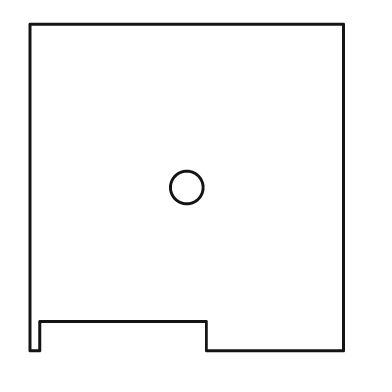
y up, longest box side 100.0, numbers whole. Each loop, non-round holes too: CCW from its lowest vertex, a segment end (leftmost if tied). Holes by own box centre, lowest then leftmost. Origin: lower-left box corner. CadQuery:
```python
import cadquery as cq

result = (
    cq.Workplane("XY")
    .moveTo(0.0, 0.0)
    .lineTo(3.0, 0.0)
    .lineTo(3.0, 9.0)
    .lineTo(54.0, 9.0)
    .lineTo(54.0, 0.0)
    .lineTo(96.0, 0.0)
    .lineTo(96.0, 100.0)
    .lineTo(0.0, 100.0)
    .close()
    .moveTo(48.0, 50.0)
    .circle(5.0)
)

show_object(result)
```